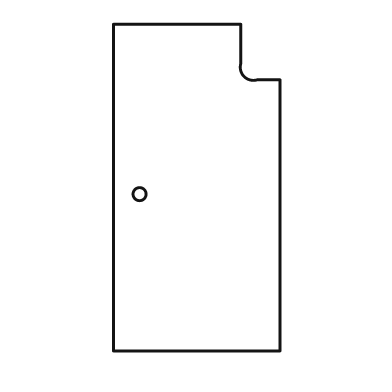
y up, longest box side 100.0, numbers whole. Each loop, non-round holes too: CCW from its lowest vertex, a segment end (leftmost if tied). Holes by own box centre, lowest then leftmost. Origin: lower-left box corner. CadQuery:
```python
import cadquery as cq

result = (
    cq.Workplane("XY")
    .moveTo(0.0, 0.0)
    .lineTo(51.0, 0.0)
    .lineTo(51.0, 83.0)
    .lineTo(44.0, 83.0)
    .threePointArc((40.0, 84.0), (39.0, 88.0))
    .lineTo(39.0, 100.0)
    .lineTo(0.0, 100.0)
    .close()
    .moveTo(8.0, 48.0)
    .circle(2.0)
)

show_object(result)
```